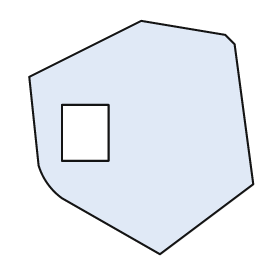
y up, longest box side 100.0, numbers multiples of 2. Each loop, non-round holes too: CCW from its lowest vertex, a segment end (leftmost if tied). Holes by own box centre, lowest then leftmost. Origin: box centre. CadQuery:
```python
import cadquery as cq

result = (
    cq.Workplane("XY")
    .moveTo(8.0, -50.0)
    .lineTo(48.0, -20.0)
    .lineTo(40.0, 40.0)
    .lineTo(36.0, 44.0)
    .lineTo(0.0, 50.0)
    .lineTo(-48.0, 26.0)
    .lineTo(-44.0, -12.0)
    .threePointArc((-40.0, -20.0), (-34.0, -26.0))
    .close()
    .moveTo(-34.0, -10.0)
    .lineTo(-14.0, -10.0)
    .lineTo(-14.0, 14.0)
    .lineTo(-34.0, 14.0)
    .close()
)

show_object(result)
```